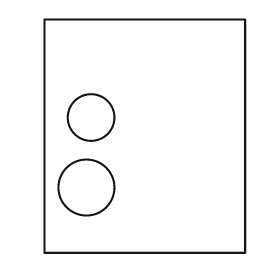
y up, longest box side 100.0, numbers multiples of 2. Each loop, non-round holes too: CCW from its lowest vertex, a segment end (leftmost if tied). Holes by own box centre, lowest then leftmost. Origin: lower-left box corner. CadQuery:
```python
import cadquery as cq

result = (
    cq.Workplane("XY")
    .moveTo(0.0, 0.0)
    .lineTo(86.0, 0.0)
    .lineTo(86.0, 100.0)
    .lineTo(0.0, 100.0)
    .close()
    .moveTo(18.0, 28.0)
    .circle(12.0)
    .moveTo(20.0, 58.0)
    .circle(10.0)
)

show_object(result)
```